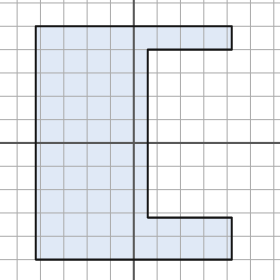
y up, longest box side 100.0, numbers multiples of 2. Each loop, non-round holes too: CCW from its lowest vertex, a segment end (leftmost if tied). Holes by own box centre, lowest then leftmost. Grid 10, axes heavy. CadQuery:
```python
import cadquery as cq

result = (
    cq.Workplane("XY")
    .moveTo(-42.0, -50.0)
    .lineTo(42.0, -50.0)
    .lineTo(42.0, -32.0)
    .lineTo(6.0, -32.0)
    .lineTo(6.0, 40.0)
    .lineTo(42.0, 40.0)
    .lineTo(42.0, 50.0)
    .lineTo(-42.0, 50.0)
    .close()
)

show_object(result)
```